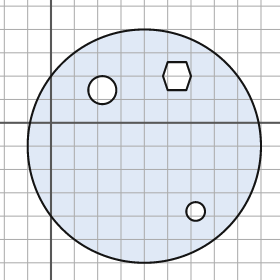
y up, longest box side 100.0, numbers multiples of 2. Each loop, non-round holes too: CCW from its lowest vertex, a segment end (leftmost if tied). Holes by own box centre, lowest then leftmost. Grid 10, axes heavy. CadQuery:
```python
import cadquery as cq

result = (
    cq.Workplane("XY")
    .moveTo(40.0, -10.0)
    .circle(50.0)
    .moveTo(62.0, -38.0)
    .circle(4.0)
    .moveTo(22.0, 14.0)
    .circle(6.0)
    .moveTo(50.0, 14.0)
    .lineTo(58.0, 14.0)
    .lineTo(60.0, 20.0)
    .lineTo(58.0, 26.0)
    .lineTo(50.0, 26.0)
    .lineTo(48.0, 20.0)
    .close()
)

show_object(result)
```